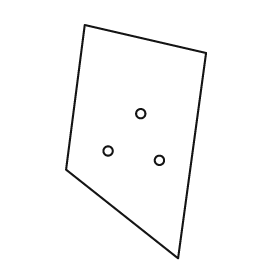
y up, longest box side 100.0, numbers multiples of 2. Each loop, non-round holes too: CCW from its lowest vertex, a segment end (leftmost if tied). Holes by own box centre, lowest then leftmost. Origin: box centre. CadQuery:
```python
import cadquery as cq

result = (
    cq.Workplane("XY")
    .moveTo(18.0, -50.0)
    .lineTo(30.0, 38.0)
    .lineTo(-22.0, 50.0)
    .lineTo(-30.0, -12.0)
    .close()
    .moveTo(10.0, -8.0)
    .circle(2.0)
    .moveTo(-12.0, -4.0)
    .circle(2.0)
    .moveTo(2.0, 12.0)
    .circle(2.0)
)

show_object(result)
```